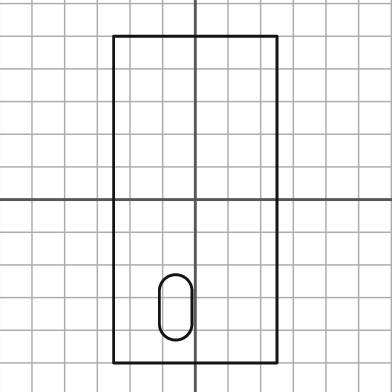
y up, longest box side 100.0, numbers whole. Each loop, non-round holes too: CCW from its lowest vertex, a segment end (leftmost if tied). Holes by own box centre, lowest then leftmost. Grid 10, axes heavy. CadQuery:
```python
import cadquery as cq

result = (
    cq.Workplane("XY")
    .moveTo(-25.0, -50.0)
    .lineTo(25.0, -50.0)
    .lineTo(25.0, 50.0)
    .lineTo(-25.0, 50.0)
    .close()
    .moveTo(-11.0, -38.0)
    .threePointArc((-6.0, -43.0), (-1.0, -38.0))
    .lineTo(-1.0, -28.0)
    .threePointArc((-6.0, -23.0), (-11.0, -28.0))
    .close()
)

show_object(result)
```